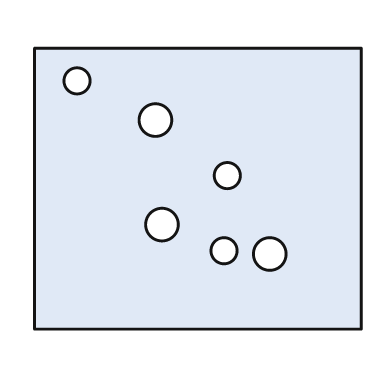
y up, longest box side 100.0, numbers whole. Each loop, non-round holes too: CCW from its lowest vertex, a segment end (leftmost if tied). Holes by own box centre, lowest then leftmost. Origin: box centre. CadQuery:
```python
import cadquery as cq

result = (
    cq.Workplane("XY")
    .moveTo(-50.0, -43.0)
    .lineTo(50.0, -43.0)
    .lineTo(50.0, 43.0)
    .lineTo(-50.0, 43.0)
    .close()
    .moveTo(22.0, -20.0)
    .circle(5.0)
    .moveTo(8.0, -19.0)
    .circle(4.0)
    .moveTo(-11.0, -11.0)
    .circle(5.0)
    .moveTo(9.0, 4.0)
    .circle(4.0)
    .moveTo(-13.0, 21.0)
    .circle(5.0)
    .moveTo(-37.0, 33.0)
    .circle(4.0)
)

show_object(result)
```